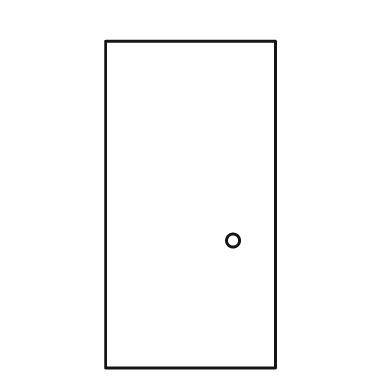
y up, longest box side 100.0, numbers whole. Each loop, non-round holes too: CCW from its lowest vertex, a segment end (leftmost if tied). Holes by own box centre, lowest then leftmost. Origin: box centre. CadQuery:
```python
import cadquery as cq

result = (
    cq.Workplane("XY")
    .moveTo(-26.0, -50.0)
    .lineTo(26.0, -50.0)
    .lineTo(26.0, 50.0)
    .lineTo(-26.0, 50.0)
    .close()
    .moveTo(13.0, -11.0)
    .circle(2.0)
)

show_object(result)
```